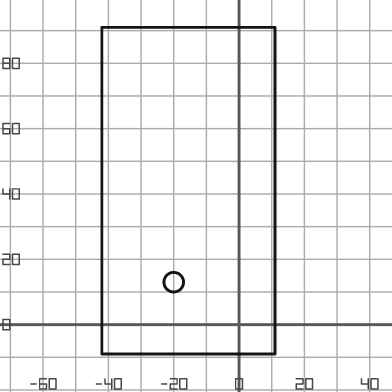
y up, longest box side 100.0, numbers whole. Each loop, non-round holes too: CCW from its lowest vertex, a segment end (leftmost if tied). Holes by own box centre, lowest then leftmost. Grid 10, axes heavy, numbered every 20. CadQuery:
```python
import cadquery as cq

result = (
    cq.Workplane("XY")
    .moveTo(-42.0, -9.0)
    .lineTo(11.0, -9.0)
    .lineTo(11.0, 91.0)
    .lineTo(-42.0, 91.0)
    .close()
    .moveTo(-20.0, 13.0)
    .circle(3.0)
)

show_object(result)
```